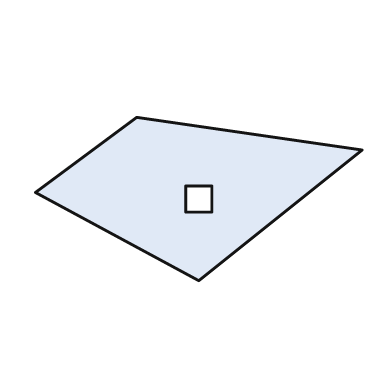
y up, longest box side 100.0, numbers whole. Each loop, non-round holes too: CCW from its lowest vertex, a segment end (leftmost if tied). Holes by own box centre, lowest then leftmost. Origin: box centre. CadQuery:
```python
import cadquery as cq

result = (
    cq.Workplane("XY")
    .moveTo(0.0, -25.0)
    .lineTo(50.0, 15.0)
    .lineTo(-19.0, 25.0)
    .lineTo(-50.0, 2.0)
    .close()
    .moveTo(-4.0, -4.0)
    .lineTo(4.0, -4.0)
    .lineTo(4.0, 4.0)
    .lineTo(-4.0, 4.0)
    .close()
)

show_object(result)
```